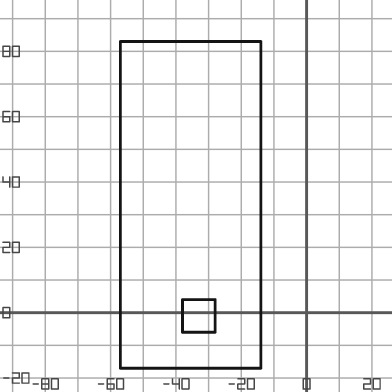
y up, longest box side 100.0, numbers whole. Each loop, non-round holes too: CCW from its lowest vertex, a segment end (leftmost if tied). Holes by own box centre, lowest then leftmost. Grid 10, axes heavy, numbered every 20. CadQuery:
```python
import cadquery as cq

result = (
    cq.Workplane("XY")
    .moveTo(-57.0, -17.0)
    .lineTo(-14.0, -17.0)
    .lineTo(-14.0, 83.0)
    .lineTo(-57.0, 83.0)
    .close()
    .moveTo(-38.0, -6.0)
    .lineTo(-28.0, -6.0)
    .lineTo(-28.0, 4.0)
    .lineTo(-38.0, 4.0)
    .close()
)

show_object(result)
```